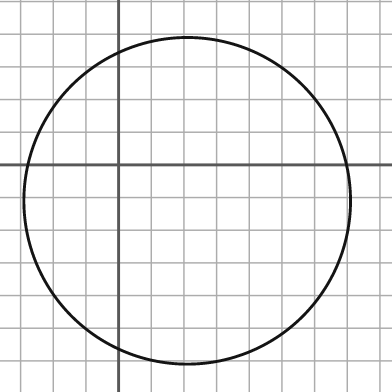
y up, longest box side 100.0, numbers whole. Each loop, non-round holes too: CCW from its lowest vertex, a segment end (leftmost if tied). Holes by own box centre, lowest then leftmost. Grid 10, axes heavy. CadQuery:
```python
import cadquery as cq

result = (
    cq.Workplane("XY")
    .moveTo(21.0, -11.0)
    .circle(50.0)
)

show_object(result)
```